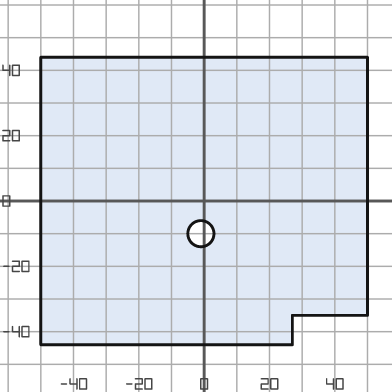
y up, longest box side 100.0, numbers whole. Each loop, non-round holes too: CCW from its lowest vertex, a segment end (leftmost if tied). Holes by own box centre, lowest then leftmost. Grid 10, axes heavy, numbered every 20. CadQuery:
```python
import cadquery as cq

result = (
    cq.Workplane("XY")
    .moveTo(-50.0, -44.0)
    .lineTo(27.0, -44.0)
    .lineTo(27.0, -35.0)
    .lineTo(50.0, -35.0)
    .lineTo(50.0, 44.0)
    .lineTo(-50.0, 44.0)
    .close()
    .moveTo(-1.0, -10.0)
    .circle(4.0)
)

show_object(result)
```